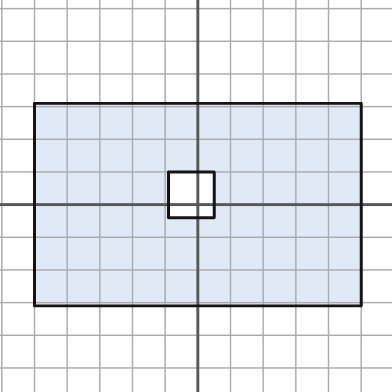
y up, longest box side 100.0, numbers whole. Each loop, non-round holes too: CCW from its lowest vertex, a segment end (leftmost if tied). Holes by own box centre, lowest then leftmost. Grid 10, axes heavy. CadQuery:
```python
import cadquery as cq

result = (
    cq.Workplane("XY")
    .moveTo(-50.0, -31.0)
    .lineTo(50.0, -31.0)
    .lineTo(50.0, 31.0)
    .lineTo(-50.0, 31.0)
    .close()
    .moveTo(-9.0, -4.0)
    .lineTo(5.0, -4.0)
    .lineTo(5.0, 10.0)
    .lineTo(-9.0, 10.0)
    .close()
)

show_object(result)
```